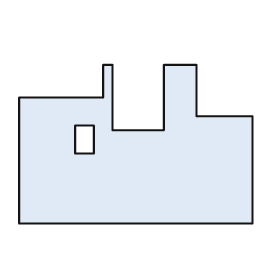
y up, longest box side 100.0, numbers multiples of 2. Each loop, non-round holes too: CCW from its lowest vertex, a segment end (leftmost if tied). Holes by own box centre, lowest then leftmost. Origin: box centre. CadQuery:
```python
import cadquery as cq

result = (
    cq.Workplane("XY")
    .moveTo(-50.0, -34.0)
    .lineTo(50.0, -34.0)
    .lineTo(50.0, 12.0)
    .lineTo(26.0, 12.0)
    .lineTo(26.0, 34.0)
    .lineTo(12.0, 34.0)
    .lineTo(12.0, 6.0)
    .lineTo(-10.0, 6.0)
    .lineTo(-10.0, 34.0)
    .lineTo(-14.0, 34.0)
    .lineTo(-14.0, 20.0)
    .lineTo(-50.0, 20.0)
    .close()
    .moveTo(-26.0, -4.0)
    .lineTo(-18.0, -4.0)
    .lineTo(-18.0, 8.0)
    .lineTo(-26.0, 8.0)
    .close()
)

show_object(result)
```